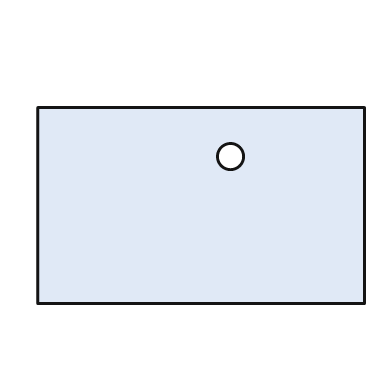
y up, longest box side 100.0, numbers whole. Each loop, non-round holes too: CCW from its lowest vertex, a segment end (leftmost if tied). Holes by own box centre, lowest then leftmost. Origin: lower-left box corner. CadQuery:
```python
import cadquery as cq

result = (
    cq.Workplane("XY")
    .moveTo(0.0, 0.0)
    .lineTo(100.0, 0.0)
    .lineTo(100.0, 60.0)
    .lineTo(0.0, 60.0)
    .close()
    .moveTo(59.0, 45.0)
    .circle(4.0)
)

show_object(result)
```